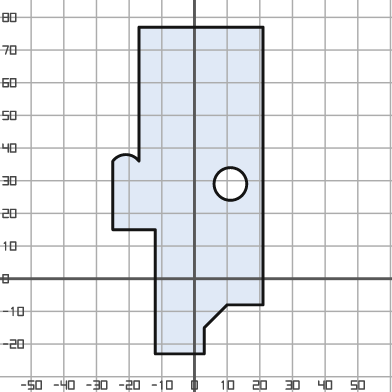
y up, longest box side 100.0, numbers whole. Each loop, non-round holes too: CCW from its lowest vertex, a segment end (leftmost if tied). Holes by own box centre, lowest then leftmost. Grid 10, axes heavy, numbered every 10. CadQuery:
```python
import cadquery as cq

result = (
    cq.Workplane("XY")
    .moveTo(-12.0, -23.0)
    .lineTo(3.0, -23.0)
    .lineTo(3.0, -15.0)
    .lineTo(10.0, -8.0)
    .lineTo(21.0, -8.0)
    .lineTo(21.0, 77.0)
    .lineTo(-17.0, 77.0)
    .lineTo(-17.0, 36.0)
    .threePointArc((-21.0, 38.0), (-25.0, 36.0))
    .lineTo(-25.0, 15.0)
    .lineTo(-12.0, 15.0)
    .close()
    .moveTo(11.0, 29.0)
    .circle(5.0)
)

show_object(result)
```